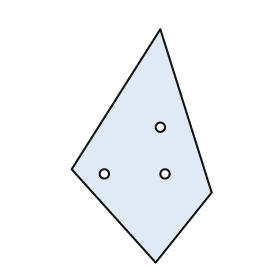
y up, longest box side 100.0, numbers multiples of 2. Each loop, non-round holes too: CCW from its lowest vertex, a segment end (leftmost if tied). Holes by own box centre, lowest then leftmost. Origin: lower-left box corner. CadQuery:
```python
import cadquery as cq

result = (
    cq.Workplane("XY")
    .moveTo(36.0, 0.0)
    .lineTo(60.0, 30.0)
    .lineTo(38.0, 100.0)
    .lineTo(0.0, 40.0)
    .close()
    .moveTo(14.0, 38.0)
    .circle(2.0)
    .moveTo(40.0, 38.0)
    .circle(2.0)
    .moveTo(38.0, 58.0)
    .circle(2.0)
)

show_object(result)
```